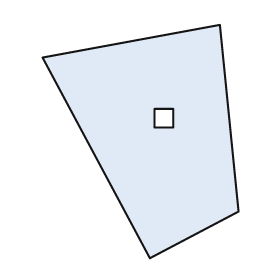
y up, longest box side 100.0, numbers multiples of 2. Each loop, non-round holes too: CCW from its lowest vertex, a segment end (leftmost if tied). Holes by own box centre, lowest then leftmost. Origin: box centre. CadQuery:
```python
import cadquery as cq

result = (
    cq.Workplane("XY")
    .moveTo(4.0, -50.0)
    .lineTo(42.0, -30.0)
    .lineTo(34.0, 50.0)
    .lineTo(-42.0, 36.0)
    .close()
    .moveTo(6.0, 6.0)
    .lineTo(14.0, 6.0)
    .lineTo(14.0, 14.0)
    .lineTo(6.0, 14.0)
    .close()
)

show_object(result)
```